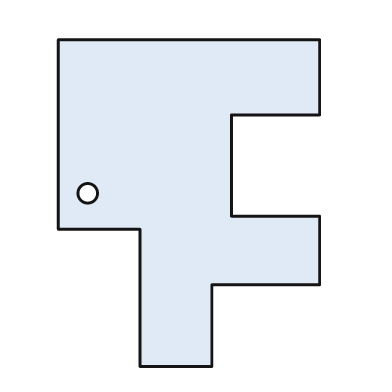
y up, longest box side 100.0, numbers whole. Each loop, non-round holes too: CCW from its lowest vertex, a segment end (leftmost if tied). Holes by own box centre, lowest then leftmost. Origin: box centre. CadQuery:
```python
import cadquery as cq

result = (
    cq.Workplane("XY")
    .moveTo(-15.0, -50.0)
    .lineTo(7.0, -50.0)
    .lineTo(7.0, -25.0)
    .lineTo(40.0, -25.0)
    .lineTo(40.0, -4.0)
    .lineTo(13.0, -4.0)
    .lineTo(13.0, 27.0)
    .lineTo(40.0, 27.0)
    .lineTo(40.0, 50.0)
    .lineTo(-40.0, 50.0)
    .lineTo(-40.0, -8.0)
    .lineTo(-15.0, -8.0)
    .close()
    .moveTo(-31.0, 3.0)
    .circle(3.0)
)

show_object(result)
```